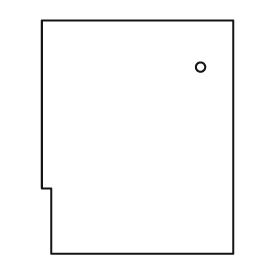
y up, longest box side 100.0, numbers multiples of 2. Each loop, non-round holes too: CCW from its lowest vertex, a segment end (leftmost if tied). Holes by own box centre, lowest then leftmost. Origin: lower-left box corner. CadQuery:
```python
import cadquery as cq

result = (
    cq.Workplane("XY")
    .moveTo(4.0, 0.0)
    .lineTo(82.0, 0.0)
    .lineTo(82.0, 100.0)
    .lineTo(0.0, 100.0)
    .lineTo(0.0, 28.0)
    .lineTo(4.0, 28.0)
    .close()
    .moveTo(68.0, 80.0)
    .circle(2.0)
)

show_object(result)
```